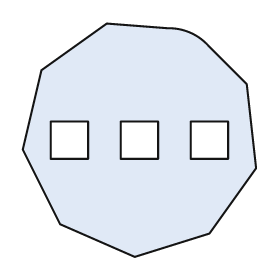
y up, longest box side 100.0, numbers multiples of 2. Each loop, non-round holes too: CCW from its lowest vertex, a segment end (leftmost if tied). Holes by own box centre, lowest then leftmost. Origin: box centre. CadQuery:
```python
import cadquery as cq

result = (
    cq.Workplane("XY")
    .moveTo(-2.0, -50.0)
    .lineTo(30.0, -40.0)
    .lineTo(50.0, -12.0)
    .lineTo(46.0, 24.0)
    .lineTo(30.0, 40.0)
    .threePointArc((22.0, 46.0), (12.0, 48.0))
    .lineTo(-14.0, 50.0)
    .lineTo(-42.0, 30.0)
    .lineTo(-50.0, -4.0)
    .lineTo(-34.0, -36.0)
    .close()
    .moveTo(-38.0, -8.0)
    .lineTo(-22.0, -8.0)
    .lineTo(-22.0, 8.0)
    .lineTo(-38.0, 8.0)
    .close()
    .moveTo(-8.0, -8.0)
    .lineTo(8.0, -8.0)
    .lineTo(8.0, 8.0)
    .lineTo(-8.0, 8.0)
    .close()
    .moveTo(22.0, -8.0)
    .lineTo(38.0, -8.0)
    .lineTo(38.0, 8.0)
    .lineTo(22.0, 8.0)
    .close()
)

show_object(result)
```